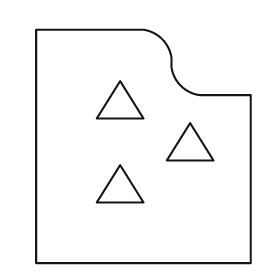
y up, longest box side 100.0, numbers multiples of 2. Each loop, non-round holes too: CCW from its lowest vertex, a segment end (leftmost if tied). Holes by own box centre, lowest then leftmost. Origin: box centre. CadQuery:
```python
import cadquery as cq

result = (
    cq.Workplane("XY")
    .moveTo(-46.0, -50.0)
    .lineTo(46.0, -50.0)
    .lineTo(46.0, 22.0)
    .lineTo(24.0, 22.0)
    .threePointArc((16.0, 26.0), (12.0, 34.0))
    .lineTo(12.0, 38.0)
    .threePointArc((8.0, 46.0), (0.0, 50.0))
    .lineTo(-46.0, 50.0)
    .close()
    .moveTo(-20.0, -24.0)
    .lineTo(0.0, -24.0)
    .lineTo(-10.0, -8.0)
    .close()
    .moveTo(10.0, -6.0)
    .lineTo(30.0, -6.0)
    .lineTo(20.0, 10.0)
    .close()
    .moveTo(-20.0, 12.0)
    .lineTo(0.0, 12.0)
    .lineTo(-10.0, 28.0)
    .close()
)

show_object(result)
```